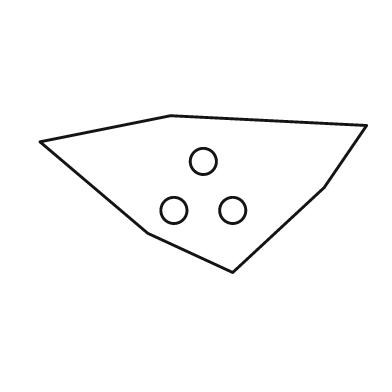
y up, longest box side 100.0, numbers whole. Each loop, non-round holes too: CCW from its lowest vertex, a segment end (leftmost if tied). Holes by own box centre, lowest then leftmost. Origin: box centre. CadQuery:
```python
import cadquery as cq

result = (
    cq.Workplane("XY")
    .moveTo(9.0, -24.0)
    .lineTo(37.0, 2.0)
    .lineTo(50.0, 21.0)
    .lineTo(-10.0, 24.0)
    .lineTo(-50.0, 16.0)
    .lineTo(-17.0, -12.0)
    .close()
    .moveTo(-9.0, -5.0)
    .circle(4.0)
    .moveTo(9.0, -5.0)
    .circle(4.0)
    .moveTo(0.0, 10.0)
    .circle(4.0)
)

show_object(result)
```